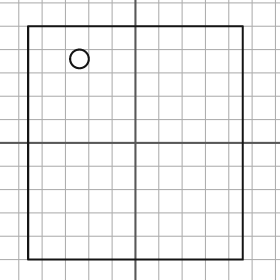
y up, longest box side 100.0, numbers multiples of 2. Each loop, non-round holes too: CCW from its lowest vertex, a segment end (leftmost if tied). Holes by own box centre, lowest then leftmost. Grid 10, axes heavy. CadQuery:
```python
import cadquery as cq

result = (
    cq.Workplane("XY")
    .moveTo(-46.0, -50.0)
    .lineTo(46.0, -50.0)
    .lineTo(46.0, 50.0)
    .lineTo(-46.0, 50.0)
    .close()
    .moveTo(-24.0, 36.0)
    .circle(4.0)
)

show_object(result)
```